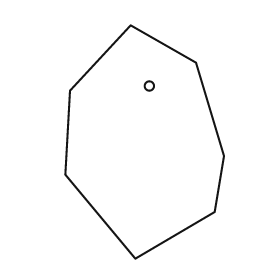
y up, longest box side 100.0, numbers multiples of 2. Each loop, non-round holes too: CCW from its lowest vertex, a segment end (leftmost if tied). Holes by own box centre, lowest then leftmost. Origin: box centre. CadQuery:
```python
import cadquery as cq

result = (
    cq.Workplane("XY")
    .moveTo(-4.0, -50.0)
    .lineTo(30.0, -30.0)
    .lineTo(34.0, -6.0)
    .lineTo(22.0, 34.0)
    .lineTo(-6.0, 50.0)
    .lineTo(-32.0, 22.0)
    .lineTo(-34.0, -14.0)
    .close()
    .moveTo(2.0, 24.0)
    .circle(2.0)
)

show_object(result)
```